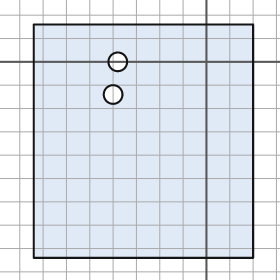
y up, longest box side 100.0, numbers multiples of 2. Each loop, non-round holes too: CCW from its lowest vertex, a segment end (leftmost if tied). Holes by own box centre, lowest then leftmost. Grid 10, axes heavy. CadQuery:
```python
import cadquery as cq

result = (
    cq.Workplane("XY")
    .moveTo(-74.0, -84.0)
    .lineTo(20.0, -84.0)
    .lineTo(20.0, 16.0)
    .lineTo(-74.0, 16.0)
    .close()
    .moveTo(-40.0, -14.0)
    .circle(4.0)
    .moveTo(-38.0, 0.0)
    .circle(4.0)
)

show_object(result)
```